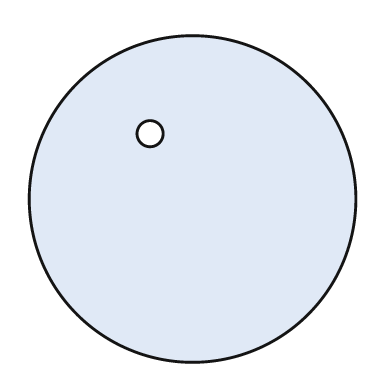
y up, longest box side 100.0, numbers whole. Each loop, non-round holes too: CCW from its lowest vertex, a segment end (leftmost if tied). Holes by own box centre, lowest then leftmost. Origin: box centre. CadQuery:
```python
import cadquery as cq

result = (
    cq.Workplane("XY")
    .moveTo(0.0, 0.0)
    .circle(50.0)
    .moveTo(-13.0, 20.0)
    .circle(4.0)
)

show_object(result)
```